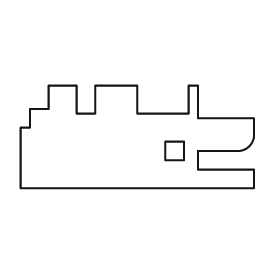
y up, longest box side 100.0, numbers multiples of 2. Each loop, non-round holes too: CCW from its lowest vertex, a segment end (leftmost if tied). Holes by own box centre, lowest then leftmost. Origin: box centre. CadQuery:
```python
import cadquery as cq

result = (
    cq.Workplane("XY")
    .moveTo(-50.0, -22.0)
    .lineTo(50.0, -22.0)
    .lineTo(50.0, -14.0)
    .lineTo(26.0, -14.0)
    .lineTo(26.0, -6.0)
    .lineTo(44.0, -6.0)
    .threePointArc((48.0, -4.0), (50.0, 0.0))
    .lineTo(50.0, 8.0)
    .lineTo(26.0, 8.0)
    .lineTo(26.0, 22.0)
    .lineTo(22.0, 22.0)
    .lineTo(22.0, 10.0)
    .lineTo(0.0, 10.0)
    .lineTo(0.0, 22.0)
    .lineTo(-18.0, 22.0)
    .lineTo(-18.0, 10.0)
    .lineTo(-26.0, 10.0)
    .lineTo(-26.0, 22.0)
    .lineTo(-38.0, 22.0)
    .lineTo(-38.0, 12.0)
    .lineTo(-46.0, 12.0)
    .lineTo(-46.0, 4.0)
    .lineTo(-50.0, 4.0)
    .close()
    .moveTo(12.0, -10.0)
    .lineTo(20.0, -10.0)
    .lineTo(20.0, -2.0)
    .lineTo(12.0, -2.0)
    .close()
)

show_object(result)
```